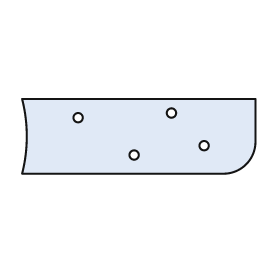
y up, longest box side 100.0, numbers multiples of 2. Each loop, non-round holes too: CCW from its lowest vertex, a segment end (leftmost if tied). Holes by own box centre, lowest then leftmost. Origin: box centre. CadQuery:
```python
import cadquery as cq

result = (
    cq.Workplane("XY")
    .moveTo(-50.0, -16.0)
    .lineTo(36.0, -16.0)
    .threePointArc((46.0, -12.0), (50.0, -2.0))
    .lineTo(50.0, 16.0)
    .lineTo(-50.0, 16.0)
    .threePointArc((-48.0, 0.0), (-50.0, -16.0))
    .close()
    .moveTo(-2.0, -8.0)
    .circle(2.0)
    .moveTo(28.0, -4.0)
    .circle(2.0)
    .moveTo(-26.0, 8.0)
    .circle(2.0)
    .moveTo(14.0, 10.0)
    .circle(2.0)
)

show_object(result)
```